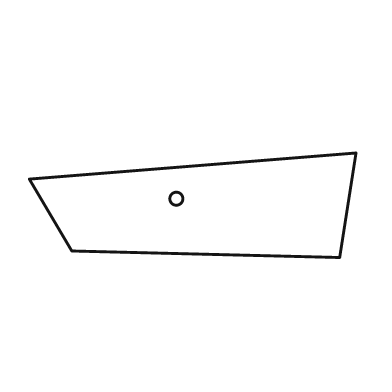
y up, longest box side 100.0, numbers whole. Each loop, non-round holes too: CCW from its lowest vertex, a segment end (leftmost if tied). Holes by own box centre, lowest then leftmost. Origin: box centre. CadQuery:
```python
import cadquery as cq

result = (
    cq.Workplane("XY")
    .moveTo(45.0, -16.0)
    .lineTo(50.0, 16.0)
    .lineTo(-50.0, 8.0)
    .lineTo(-37.0, -14.0)
    .close()
    .moveTo(-5.0, 2.0)
    .circle(2.0)
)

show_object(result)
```